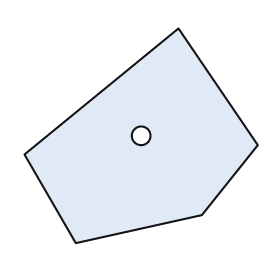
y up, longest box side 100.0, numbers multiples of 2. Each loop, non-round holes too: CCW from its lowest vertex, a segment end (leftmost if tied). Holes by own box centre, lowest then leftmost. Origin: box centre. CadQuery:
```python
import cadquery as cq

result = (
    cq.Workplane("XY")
    .moveTo(-28.0, -46.0)
    .lineTo(26.0, -34.0)
    .lineTo(50.0, -4.0)
    .lineTo(16.0, 46.0)
    .lineTo(-50.0, -8.0)
    .close()
    .moveTo(0.0, 0.0)
    .circle(4.0)
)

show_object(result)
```